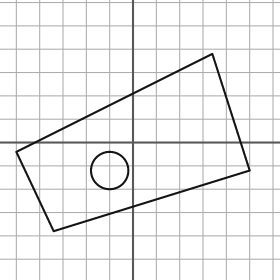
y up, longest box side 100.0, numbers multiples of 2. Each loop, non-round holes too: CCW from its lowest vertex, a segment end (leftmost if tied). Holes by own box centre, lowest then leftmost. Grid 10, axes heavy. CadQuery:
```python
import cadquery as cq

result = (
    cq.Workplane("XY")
    .moveTo(-34.0, -38.0)
    .lineTo(50.0, -12.0)
    .lineTo(34.0, 38.0)
    .lineTo(-50.0, -4.0)
    .close()
    .moveTo(-10.0, -12.0)
    .circle(8.0)
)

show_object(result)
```